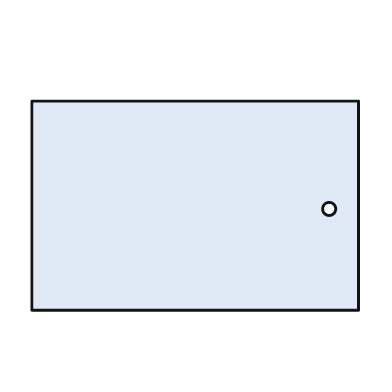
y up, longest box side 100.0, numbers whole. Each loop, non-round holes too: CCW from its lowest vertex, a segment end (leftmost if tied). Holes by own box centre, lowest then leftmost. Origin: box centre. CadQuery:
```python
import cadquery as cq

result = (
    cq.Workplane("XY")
    .moveTo(-50.0, -32.0)
    .lineTo(50.0, -32.0)
    .lineTo(50.0, 32.0)
    .lineTo(-50.0, 32.0)
    .close()
    .moveTo(41.0, -1.0)
    .circle(2.0)
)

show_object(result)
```